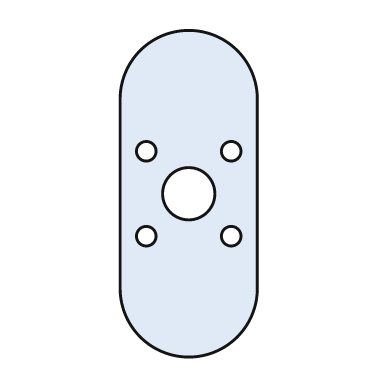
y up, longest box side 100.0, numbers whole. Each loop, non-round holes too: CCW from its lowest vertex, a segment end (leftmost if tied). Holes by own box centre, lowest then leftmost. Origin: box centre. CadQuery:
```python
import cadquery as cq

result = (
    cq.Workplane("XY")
    .moveTo(-21.0, -29.0)
    .threePointArc((0.0, -50.0), (21.0, -29.0))
    .lineTo(21.0, 29.0)
    .threePointArc((0.0, 50.0), (-21.0, 29.0))
    .close()
    .moveTo(-13.0, -13.0)
    .circle(3.0)
    .moveTo(13.0, -13.0)
    .circle(3.0)
    .moveTo(0.0, 0.0)
    .circle(8.0)
    .moveTo(-13.0, 13.0)
    .circle(3.0)
    .moveTo(13.0, 13.0)
    .circle(3.0)
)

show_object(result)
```